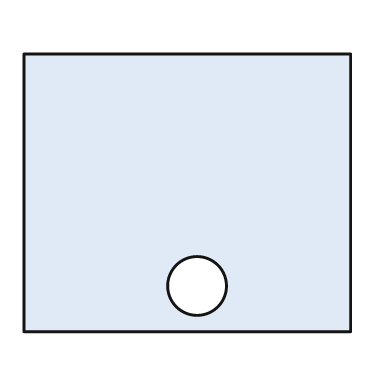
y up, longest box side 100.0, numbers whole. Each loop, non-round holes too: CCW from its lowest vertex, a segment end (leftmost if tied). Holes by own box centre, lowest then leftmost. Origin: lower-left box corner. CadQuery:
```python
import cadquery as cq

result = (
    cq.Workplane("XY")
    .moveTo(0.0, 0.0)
    .lineTo(100.0, 0.0)
    .lineTo(100.0, 85.0)
    .lineTo(0.0, 85.0)
    .close()
    .moveTo(53.0, 14.0)
    .circle(9.0)
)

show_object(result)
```